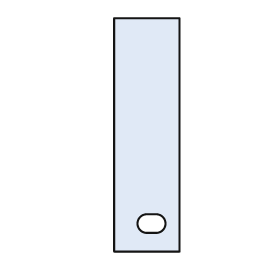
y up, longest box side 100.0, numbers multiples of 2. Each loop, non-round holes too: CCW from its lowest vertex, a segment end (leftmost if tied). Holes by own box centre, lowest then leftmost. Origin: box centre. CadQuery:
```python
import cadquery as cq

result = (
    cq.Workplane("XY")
    .moveTo(-14.0, -50.0)
    .lineTo(14.0, -50.0)
    .lineTo(14.0, 50.0)
    .lineTo(-14.0, 50.0)
    .close()
    .moveTo(0.0, -42.0)
    .lineTo(4.0, -42.0)
    .threePointArc((8.0, -38.0), (4.0, -34.0))
    .lineTo(0.0, -34.0)
    .threePointArc((-4.0, -38.0), (0.0, -42.0))
    .close()
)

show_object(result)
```